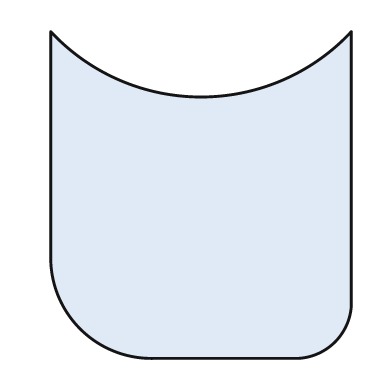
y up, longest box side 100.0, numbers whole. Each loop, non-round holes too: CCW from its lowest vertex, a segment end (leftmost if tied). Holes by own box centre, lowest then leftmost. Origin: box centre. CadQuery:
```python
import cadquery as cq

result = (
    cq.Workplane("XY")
    .moveTo(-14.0, -50.0)
    .lineTo(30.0, -50.0)
    .threePointArc((41.0, -45.0), (46.0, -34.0))
    .lineTo(46.0, 50.0)
    .threePointArc((0.0, 30.0), (-46.0, 50.0))
    .lineTo(-46.0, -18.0)
    .threePointArc((-37.0, -41.0), (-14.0, -50.0))
    .close()
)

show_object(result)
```